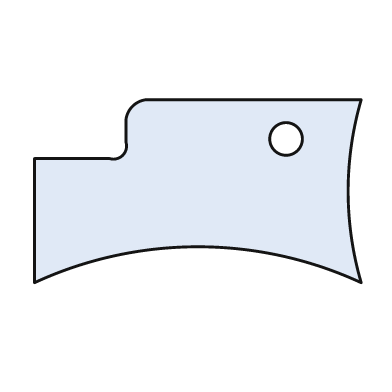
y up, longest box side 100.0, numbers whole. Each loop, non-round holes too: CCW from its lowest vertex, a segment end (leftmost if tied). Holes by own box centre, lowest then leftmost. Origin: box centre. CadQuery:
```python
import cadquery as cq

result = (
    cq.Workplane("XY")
    .moveTo(-50.0, -28.0)
    .threePointArc((0.0, -17.0), (50.0, -28.0))
    .threePointArc((46.0, 0.0), (50.0, 28.0))
    .lineTo(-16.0, 28.0)
    .threePointArc((-20.0, 26.0), (-22.0, 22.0))
    .lineTo(-22.0, 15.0)
    .threePointArc((-23.0, 11.0), (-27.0, 10.0))
    .lineTo(-50.0, 10.0)
    .close()
    .moveTo(27.0, 16.0)
    .circle(5.0)
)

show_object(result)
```